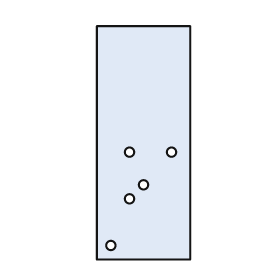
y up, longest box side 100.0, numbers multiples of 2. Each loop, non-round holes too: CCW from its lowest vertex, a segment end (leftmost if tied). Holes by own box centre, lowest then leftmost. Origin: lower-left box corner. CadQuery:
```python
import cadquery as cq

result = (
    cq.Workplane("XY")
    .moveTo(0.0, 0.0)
    .lineTo(40.0, 0.0)
    .lineTo(40.0, 100.0)
    .lineTo(0.0, 100.0)
    .close()
    .moveTo(6.0, 6.0)
    .circle(2.0)
    .moveTo(14.0, 26.0)
    .circle(2.0)
    .moveTo(20.0, 32.0)
    .circle(2.0)
    .moveTo(14.0, 46.0)
    .circle(2.0)
    .moveTo(32.0, 46.0)
    .circle(2.0)
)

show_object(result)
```